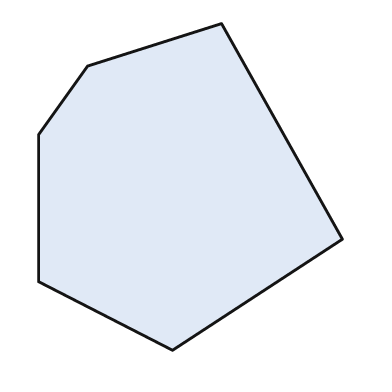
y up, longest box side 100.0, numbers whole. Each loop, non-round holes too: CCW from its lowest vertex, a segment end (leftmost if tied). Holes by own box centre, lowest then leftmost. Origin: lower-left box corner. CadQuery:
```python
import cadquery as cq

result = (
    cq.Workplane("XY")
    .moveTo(41.0, 0.0)
    .lineTo(93.0, 34.0)
    .lineTo(56.0, 100.0)
    .lineTo(15.0, 87.0)
    .lineTo(0.0, 66.0)
    .lineTo(0.0, 21.0)
    .close()
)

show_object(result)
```